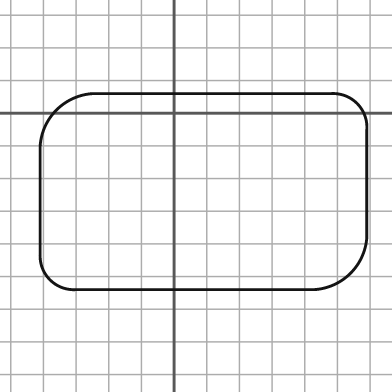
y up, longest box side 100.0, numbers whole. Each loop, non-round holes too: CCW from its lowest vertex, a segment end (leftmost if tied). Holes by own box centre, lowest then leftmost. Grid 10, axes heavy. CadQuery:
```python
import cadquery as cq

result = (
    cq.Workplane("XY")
    .moveTo(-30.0, -54.0)
    .lineTo(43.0, -54.0)
    .threePointArc((54.0, -49.0), (59.0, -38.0))
    .lineTo(59.0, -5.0)
    .threePointArc((56.0, 3.0), (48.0, 6.0))
    .lineTo(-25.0, 6.0)
    .threePointArc((-36.0, 1.0), (-41.0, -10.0))
    .lineTo(-41.0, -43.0)
    .threePointArc((-38.0, -51.0), (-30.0, -54.0))
    .close()
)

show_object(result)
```